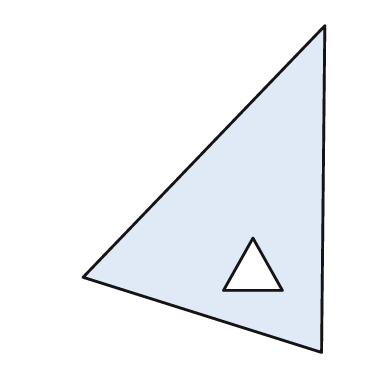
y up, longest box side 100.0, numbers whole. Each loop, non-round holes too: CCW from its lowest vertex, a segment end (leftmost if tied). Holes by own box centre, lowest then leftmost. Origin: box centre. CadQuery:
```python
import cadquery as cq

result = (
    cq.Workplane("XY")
    .moveTo(36.0, -50.0)
    .lineTo(37.0, 50.0)
    .lineTo(-37.0, -27.0)
    .close()
    .moveTo(6.0, -31.0)
    .lineTo(24.0, -31.0)
    .lineTo(15.0, -15.0)
    .close()
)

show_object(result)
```